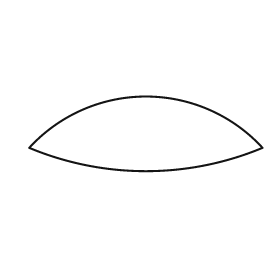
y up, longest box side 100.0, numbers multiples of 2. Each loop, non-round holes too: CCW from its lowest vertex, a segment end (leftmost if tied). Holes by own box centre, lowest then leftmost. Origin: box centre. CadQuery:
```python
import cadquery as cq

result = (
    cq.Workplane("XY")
    .moveTo(-50.0, -6.0)
    .threePointArc((0.0, -16.0), (50.0, -6.0))
    .threePointArc((0.0, 16.0), (-50.0, -6.0))
    .close()
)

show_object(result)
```